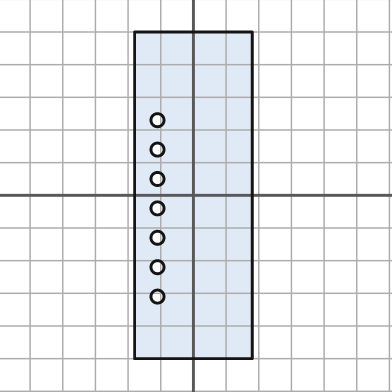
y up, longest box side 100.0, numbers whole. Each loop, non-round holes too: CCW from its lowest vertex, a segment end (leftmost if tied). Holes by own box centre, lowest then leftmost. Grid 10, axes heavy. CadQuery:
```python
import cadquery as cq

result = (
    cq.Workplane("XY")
    .moveTo(-18.0, -50.0)
    .lineTo(18.0, -50.0)
    .lineTo(18.0, 50.0)
    .lineTo(-18.0, 50.0)
    .close()
    .moveTo(-11.0, -31.0)
    .circle(2.0)
    .moveTo(-11.0, -22.0)
    .circle(2.0)
    .moveTo(-11.0, -13.0)
    .circle(2.0)
    .moveTo(-11.0, -4.0)
    .circle(2.0)
    .moveTo(-11.0, 5.0)
    .circle(2.0)
    .moveTo(-11.0, 14.0)
    .circle(2.0)
    .moveTo(-11.0, 23.0)
    .circle(2.0)
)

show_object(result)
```